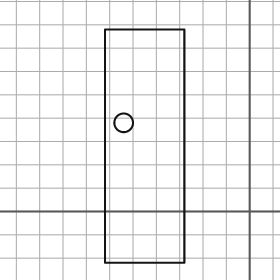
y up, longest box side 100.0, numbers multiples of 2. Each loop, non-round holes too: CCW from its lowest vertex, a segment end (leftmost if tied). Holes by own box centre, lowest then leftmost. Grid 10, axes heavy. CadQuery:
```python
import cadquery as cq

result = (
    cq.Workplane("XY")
    .moveTo(-62.0, -22.0)
    .lineTo(-28.0, -22.0)
    .lineTo(-28.0, 78.0)
    .lineTo(-62.0, 78.0)
    .close()
    .moveTo(-54.0, 38.0)
    .circle(4.0)
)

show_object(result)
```